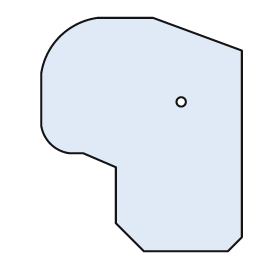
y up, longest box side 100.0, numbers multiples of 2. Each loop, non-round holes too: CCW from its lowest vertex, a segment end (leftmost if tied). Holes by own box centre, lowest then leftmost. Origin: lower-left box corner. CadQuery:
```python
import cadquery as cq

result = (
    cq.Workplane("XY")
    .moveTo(44.0, 0.0)
    .lineTo(80.0, 0.0)
    .lineTo(86.0, 6.0)
    .lineTo(86.0, 86.0)
    .lineTo(48.0, 100.0)
    .lineTo(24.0, 100.0)
    .threePointArc((8.0, 92.0), (0.0, 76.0))
    .lineTo(0.0, 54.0)
    .threePointArc((4.0, 46.0), (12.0, 42.0))
    .lineTo(18.0, 42.0)
    .lineTo(32.0, 36.0)
    .lineTo(32.0, 12.0)
    .close()
    .moveTo(60.0, 64.0)
    .circle(2.0)
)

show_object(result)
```